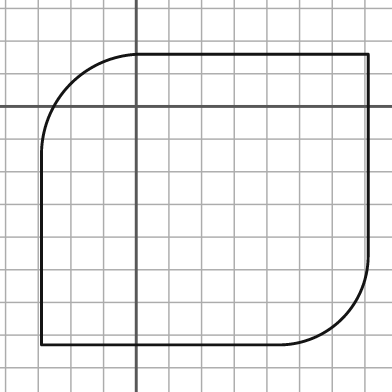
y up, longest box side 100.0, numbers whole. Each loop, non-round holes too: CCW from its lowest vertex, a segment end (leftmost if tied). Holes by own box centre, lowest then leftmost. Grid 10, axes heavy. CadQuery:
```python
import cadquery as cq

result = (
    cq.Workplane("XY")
    .moveTo(-29.0, -73.0)
    .lineTo(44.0, -73.0)
    .threePointArc((63.0, -65.0), (71.0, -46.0))
    .lineTo(71.0, 16.0)
    .lineTo(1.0, 16.0)
    .threePointArc((-20.0, 7.0), (-29.0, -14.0))
    .close()
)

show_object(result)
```